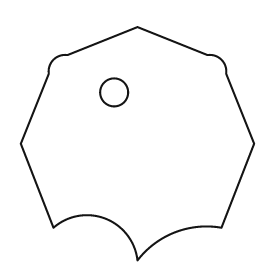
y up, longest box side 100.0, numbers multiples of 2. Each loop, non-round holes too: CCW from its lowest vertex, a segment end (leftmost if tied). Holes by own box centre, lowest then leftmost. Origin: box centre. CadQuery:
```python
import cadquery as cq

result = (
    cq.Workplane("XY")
    .moveTo(0.0, -50.0)
    .threePointArc((16.0, -38.0), (36.0, -36.0))
    .lineTo(50.0, 0.0)
    .lineTo(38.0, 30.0)
    .threePointArc((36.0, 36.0), (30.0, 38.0))
    .lineTo(0.0, 50.0)
    .lineTo(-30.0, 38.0)
    .threePointArc((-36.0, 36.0), (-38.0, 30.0))
    .lineTo(-50.0, 0.0)
    .lineTo(-36.0, -36.0)
    .threePointArc((-14.0, -32.0), (0.0, -50.0))
    .close()
    .moveTo(-10.0, 22.0)
    .circle(6.0)
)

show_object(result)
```